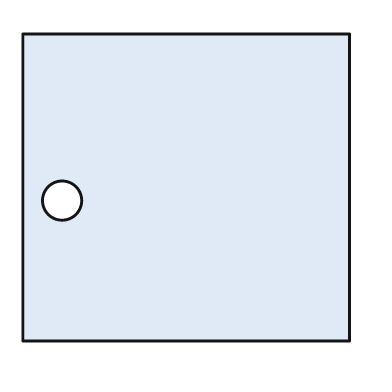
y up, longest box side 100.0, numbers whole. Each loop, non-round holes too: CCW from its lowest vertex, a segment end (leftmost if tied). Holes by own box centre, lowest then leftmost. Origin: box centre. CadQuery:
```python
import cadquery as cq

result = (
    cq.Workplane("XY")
    .moveTo(-50.0, -47.0)
    .lineTo(50.0, -47.0)
    .lineTo(50.0, 47.0)
    .lineTo(-50.0, 47.0)
    .close()
    .moveTo(-38.0, -4.0)
    .circle(6.0)
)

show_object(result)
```